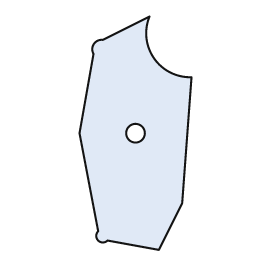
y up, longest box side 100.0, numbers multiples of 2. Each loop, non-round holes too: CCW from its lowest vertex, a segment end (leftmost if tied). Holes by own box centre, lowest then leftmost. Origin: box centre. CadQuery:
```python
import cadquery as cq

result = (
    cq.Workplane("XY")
    .moveTo(10.0, -50.0)
    .lineTo(20.0, -30.0)
    .lineTo(24.0, 24.0)
    .threePointArc((8.0, 32.0), (6.0, 50.0))
    .lineTo(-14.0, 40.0)
    .threePointArc((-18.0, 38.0), (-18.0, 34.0))
    .lineTo(-24.0, 0.0)
    .lineTo(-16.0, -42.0)
    .threePointArc((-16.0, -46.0), (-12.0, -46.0))
    .close()
    .moveTo(0.0, 0.0)
    .circle(4.0)
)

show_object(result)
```